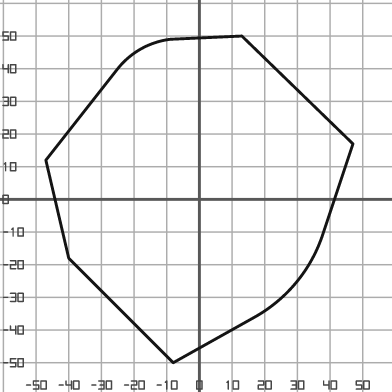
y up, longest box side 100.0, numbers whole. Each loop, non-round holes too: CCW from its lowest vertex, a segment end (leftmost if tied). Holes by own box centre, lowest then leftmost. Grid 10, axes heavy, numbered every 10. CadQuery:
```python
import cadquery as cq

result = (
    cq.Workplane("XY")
    .moveTo(-8.0, -50.0)
    .lineTo(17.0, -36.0)
    .threePointArc((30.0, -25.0), (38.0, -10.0))
    .lineTo(47.0, 17.0)
    .lineTo(13.0, 50.0)
    .lineTo(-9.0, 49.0)
    .threePointArc((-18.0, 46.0), (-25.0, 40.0))
    .lineTo(-47.0, 12.0)
    .lineTo(-40.0, -18.0)
    .close()
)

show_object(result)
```